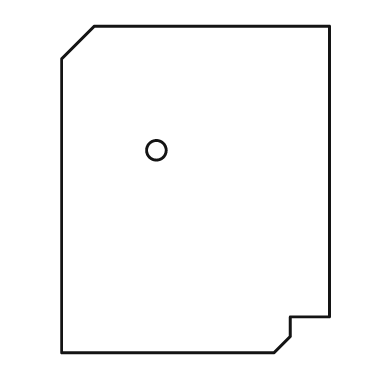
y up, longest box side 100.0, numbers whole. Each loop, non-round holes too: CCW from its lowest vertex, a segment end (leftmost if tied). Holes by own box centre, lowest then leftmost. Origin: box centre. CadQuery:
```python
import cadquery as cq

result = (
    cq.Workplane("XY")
    .moveTo(-41.0, -50.0)
    .lineTo(24.0, -50.0)
    .lineTo(29.0, -45.0)
    .lineTo(29.0, -39.0)
    .lineTo(41.0, -39.0)
    .lineTo(41.0, 50.0)
    .lineTo(-31.0, 50.0)
    .lineTo(-41.0, 40.0)
    .close()
    .moveTo(-12.0, 12.0)
    .circle(3.0)
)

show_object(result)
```